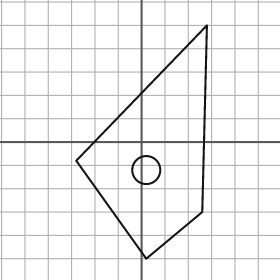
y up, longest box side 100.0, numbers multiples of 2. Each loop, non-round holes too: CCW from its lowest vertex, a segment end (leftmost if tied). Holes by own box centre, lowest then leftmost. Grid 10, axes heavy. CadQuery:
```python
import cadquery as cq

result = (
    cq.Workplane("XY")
    .moveTo(2.0, -50.0)
    .lineTo(26.0, -30.0)
    .lineTo(28.0, 50.0)
    .lineTo(-28.0, -8.0)
    .close()
    .moveTo(2.0, -12.0)
    .circle(6.0)
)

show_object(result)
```